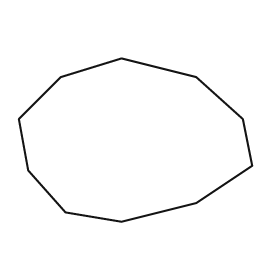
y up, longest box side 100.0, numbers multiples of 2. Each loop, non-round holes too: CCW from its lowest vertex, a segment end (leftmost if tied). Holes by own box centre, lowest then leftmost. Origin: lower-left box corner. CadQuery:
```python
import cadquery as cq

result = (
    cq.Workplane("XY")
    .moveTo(44.0, 0.0)
    .lineTo(76.0, 8.0)
    .lineTo(100.0, 24.0)
    .lineTo(96.0, 44.0)
    .lineTo(76.0, 62.0)
    .lineTo(44.0, 70.0)
    .lineTo(18.0, 62.0)
    .lineTo(0.0, 44.0)
    .lineTo(4.0, 22.0)
    .lineTo(20.0, 4.0)
    .close()
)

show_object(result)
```